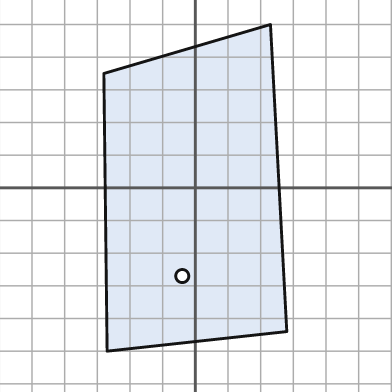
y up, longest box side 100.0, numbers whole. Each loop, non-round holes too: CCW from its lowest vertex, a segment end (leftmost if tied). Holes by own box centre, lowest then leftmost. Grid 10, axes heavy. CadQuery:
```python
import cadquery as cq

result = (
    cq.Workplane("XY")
    .moveTo(-27.0, -50.0)
    .lineTo(28.0, -44.0)
    .lineTo(23.0, 50.0)
    .lineTo(-28.0, 35.0)
    .close()
    .moveTo(-4.0, -27.0)
    .circle(2.0)
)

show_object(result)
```